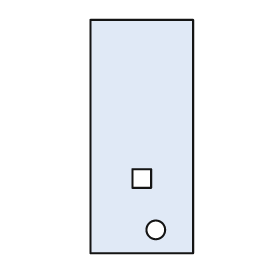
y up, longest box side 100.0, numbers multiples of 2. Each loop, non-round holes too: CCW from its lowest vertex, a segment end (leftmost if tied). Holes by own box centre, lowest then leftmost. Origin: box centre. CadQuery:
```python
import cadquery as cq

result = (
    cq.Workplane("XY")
    .moveTo(-22.0, -50.0)
    .lineTo(22.0, -50.0)
    .lineTo(22.0, 50.0)
    .lineTo(-22.0, 50.0)
    .close()
    .moveTo(6.0, -40.0)
    .circle(4.0)
    .moveTo(-4.0, -22.0)
    .lineTo(4.0, -22.0)
    .lineTo(4.0, -14.0)
    .lineTo(-4.0, -14.0)
    .close()
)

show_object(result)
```